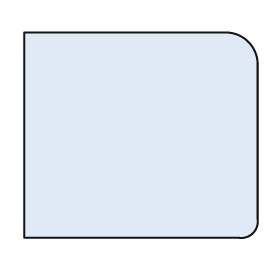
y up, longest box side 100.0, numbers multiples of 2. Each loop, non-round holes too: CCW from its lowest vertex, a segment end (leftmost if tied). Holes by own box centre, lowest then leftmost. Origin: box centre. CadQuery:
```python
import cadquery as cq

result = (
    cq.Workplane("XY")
    .moveTo(-50.0, -44.0)
    .lineTo(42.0, -44.0)
    .threePointArc((48.0, -42.0), (50.0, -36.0))
    .lineTo(50.0, 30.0)
    .threePointArc((46.0, 40.0), (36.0, 44.0))
    .lineTo(-50.0, 44.0)
    .close()
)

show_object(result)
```